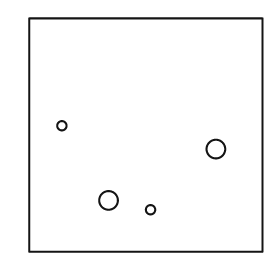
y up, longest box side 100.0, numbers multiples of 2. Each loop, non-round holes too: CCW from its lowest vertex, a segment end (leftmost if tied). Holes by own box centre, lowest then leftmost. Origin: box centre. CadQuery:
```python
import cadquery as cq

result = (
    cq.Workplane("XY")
    .moveTo(-50.0, -50.0)
    .lineTo(50.0, -50.0)
    .lineTo(50.0, 50.0)
    .lineTo(-50.0, 50.0)
    .close()
    .moveTo(2.0, -32.0)
    .circle(2.0)
    .moveTo(-16.0, -28.0)
    .circle(4.0)
    .moveTo(30.0, -6.0)
    .circle(4.0)
    .moveTo(-36.0, 4.0)
    .circle(2.0)
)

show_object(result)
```